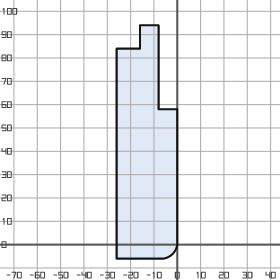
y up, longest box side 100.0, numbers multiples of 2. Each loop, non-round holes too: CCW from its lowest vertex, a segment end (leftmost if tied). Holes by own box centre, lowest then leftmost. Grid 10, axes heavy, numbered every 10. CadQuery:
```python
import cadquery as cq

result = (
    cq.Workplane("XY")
    .moveTo(-26.0, -6.0)
    .lineTo(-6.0, -6.0)
    .threePointArc((-2.0, -4.0), (0.0, 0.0))
    .lineTo(0.0, 58.0)
    .lineTo(-8.0, 58.0)
    .lineTo(-8.0, 94.0)
    .lineTo(-16.0, 94.0)
    .lineTo(-16.0, 84.0)
    .lineTo(-26.0, 84.0)
    .close()
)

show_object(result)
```